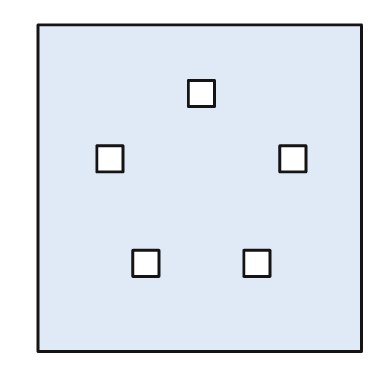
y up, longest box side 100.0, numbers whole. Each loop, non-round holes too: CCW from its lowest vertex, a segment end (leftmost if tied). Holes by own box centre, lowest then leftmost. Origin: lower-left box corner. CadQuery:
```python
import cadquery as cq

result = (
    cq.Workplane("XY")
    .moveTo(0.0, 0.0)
    .lineTo(99.0, 0.0)
    .lineTo(99.0, 100.0)
    .lineTo(0.0, 100.0)
    .close()
    .moveTo(29.0, 23.0)
    .lineTo(37.0, 23.0)
    .lineTo(37.0, 31.0)
    .lineTo(29.0, 31.0)
    .close()
    .moveTo(63.0, 23.0)
    .lineTo(71.0, 23.0)
    .lineTo(71.0, 31.0)
    .lineTo(63.0, 31.0)
    .close()
    .moveTo(18.0, 55.0)
    .lineTo(26.0, 55.0)
    .lineTo(26.0, 63.0)
    .lineTo(18.0, 63.0)
    .close()
    .moveTo(74.0, 55.0)
    .lineTo(82.0, 55.0)
    .lineTo(82.0, 63.0)
    .lineTo(74.0, 63.0)
    .close()
    .moveTo(46.0, 75.0)
    .lineTo(54.0, 75.0)
    .lineTo(54.0, 83.0)
    .lineTo(46.0, 83.0)
    .close()
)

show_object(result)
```